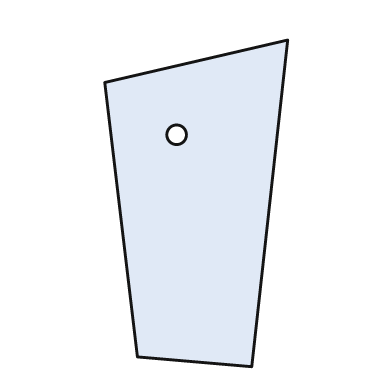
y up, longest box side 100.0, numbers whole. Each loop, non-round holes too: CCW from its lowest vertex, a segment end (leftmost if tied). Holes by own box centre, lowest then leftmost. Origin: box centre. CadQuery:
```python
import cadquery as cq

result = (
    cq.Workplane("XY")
    .moveTo(17.0, -50.0)
    .lineTo(28.0, 50.0)
    .lineTo(-28.0, 37.0)
    .lineTo(-18.0, -47.0)
    .close()
    .moveTo(-6.0, 21.0)
    .circle(3.0)
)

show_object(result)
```